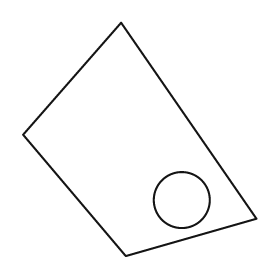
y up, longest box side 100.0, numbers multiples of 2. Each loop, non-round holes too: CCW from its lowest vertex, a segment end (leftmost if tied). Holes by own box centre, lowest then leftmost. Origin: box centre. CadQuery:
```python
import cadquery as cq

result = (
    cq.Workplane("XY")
    .moveTo(-6.0, -50.0)
    .lineTo(50.0, -34.0)
    .lineTo(-8.0, 50.0)
    .lineTo(-50.0, 2.0)
    .close()
    .moveTo(18.0, -26.0)
    .circle(12.0)
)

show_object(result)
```